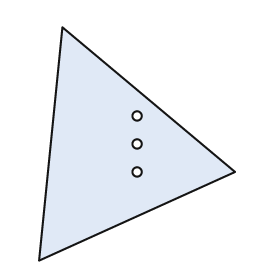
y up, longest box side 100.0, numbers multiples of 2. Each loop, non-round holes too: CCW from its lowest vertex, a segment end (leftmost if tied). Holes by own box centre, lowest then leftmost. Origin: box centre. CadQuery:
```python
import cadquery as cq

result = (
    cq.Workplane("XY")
    .moveTo(-42.0, -50.0)
    .lineTo(42.0, -12.0)
    .lineTo(-32.0, 50.0)
    .close()
    .moveTo(0.0, -12.0)
    .circle(2.0)
    .moveTo(0.0, 0.0)
    .circle(2.0)
    .moveTo(0.0, 12.0)
    .circle(2.0)
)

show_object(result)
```